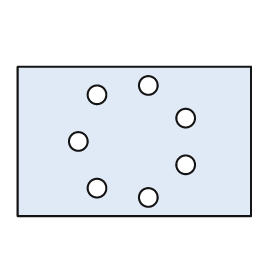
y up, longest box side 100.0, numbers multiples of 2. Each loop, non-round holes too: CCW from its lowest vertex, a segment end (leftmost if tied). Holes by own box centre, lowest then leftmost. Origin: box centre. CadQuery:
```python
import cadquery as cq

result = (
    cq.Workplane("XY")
    .moveTo(-50.0, -32.0)
    .lineTo(50.0, -32.0)
    .lineTo(50.0, 32.0)
    .lineTo(-50.0, 32.0)
    .close()
    .moveTo(6.0, -24.0)
    .circle(4.0)
    .moveTo(-16.0, -20.0)
    .circle(4.0)
    .moveTo(22.0, -10.0)
    .circle(4.0)
    .moveTo(-24.0, 0.0)
    .circle(4.0)
    .moveTo(22.0, 10.0)
    .circle(4.0)
    .moveTo(-16.0, 20.0)
    .circle(4.0)
    .moveTo(6.0, 24.0)
    .circle(4.0)
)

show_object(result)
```